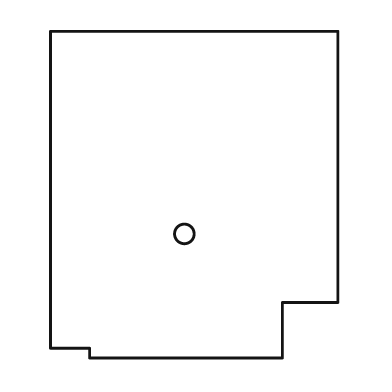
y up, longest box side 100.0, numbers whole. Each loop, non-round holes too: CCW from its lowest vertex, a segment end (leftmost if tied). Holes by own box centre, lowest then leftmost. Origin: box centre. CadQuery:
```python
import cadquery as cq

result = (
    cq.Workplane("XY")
    .moveTo(-32.0, -50.0)
    .lineTo(27.0, -50.0)
    .lineTo(27.0, -33.0)
    .lineTo(44.0, -33.0)
    .lineTo(44.0, 50.0)
    .lineTo(-44.0, 50.0)
    .lineTo(-44.0, -47.0)
    .lineTo(-32.0, -47.0)
    .close()
    .moveTo(-3.0, -12.0)
    .circle(3.0)
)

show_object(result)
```